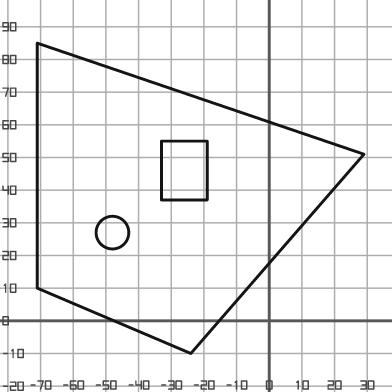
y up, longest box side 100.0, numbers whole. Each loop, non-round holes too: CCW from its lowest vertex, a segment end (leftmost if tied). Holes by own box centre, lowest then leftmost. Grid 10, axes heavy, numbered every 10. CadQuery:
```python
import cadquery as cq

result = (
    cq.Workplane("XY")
    .moveTo(-24.0, -10.0)
    .lineTo(29.0, 51.0)
    .lineTo(-71.0, 85.0)
    .lineTo(-71.0, 10.0)
    .close()
    .moveTo(-48.0, 27.0)
    .circle(5.0)
    .moveTo(-33.0, 37.0)
    .lineTo(-19.0, 37.0)
    .lineTo(-19.0, 55.0)
    .lineTo(-33.0, 55.0)
    .close()
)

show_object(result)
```